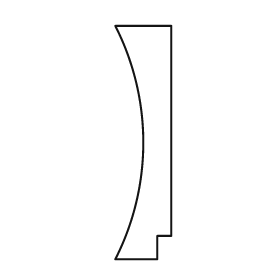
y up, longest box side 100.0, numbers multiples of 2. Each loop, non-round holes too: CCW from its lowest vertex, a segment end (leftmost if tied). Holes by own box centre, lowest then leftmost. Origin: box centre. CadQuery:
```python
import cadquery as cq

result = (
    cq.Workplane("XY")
    .moveTo(-12.0, -50.0)
    .lineTo(6.0, -50.0)
    .lineTo(6.0, -40.0)
    .lineTo(12.0, -40.0)
    .lineTo(12.0, 50.0)
    .lineTo(-12.0, 50.0)
    .threePointArc((0.0, 0.0), (-12.0, -50.0))
    .close()
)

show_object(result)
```